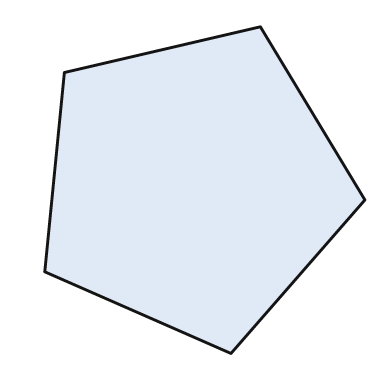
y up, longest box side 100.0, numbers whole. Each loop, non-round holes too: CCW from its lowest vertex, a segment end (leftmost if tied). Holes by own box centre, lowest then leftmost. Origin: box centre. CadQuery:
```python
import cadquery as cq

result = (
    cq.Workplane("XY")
    .moveTo(8.0, -50.0)
    .lineTo(49.0, -3.0)
    .lineTo(17.0, 50.0)
    .lineTo(-43.0, 36.0)
    .lineTo(-49.0, -25.0)
    .close()
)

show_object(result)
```